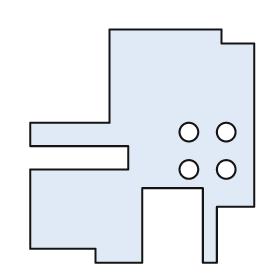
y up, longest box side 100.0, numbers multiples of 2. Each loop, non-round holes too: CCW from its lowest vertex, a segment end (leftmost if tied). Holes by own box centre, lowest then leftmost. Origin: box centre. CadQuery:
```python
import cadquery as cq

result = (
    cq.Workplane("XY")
    .moveTo(-20.0, -50.0)
    .lineTo(0.0, -50.0)
    .lineTo(0.0, -18.0)
    .lineTo(26.0, -18.0)
    .lineTo(26.0, -50.0)
    .lineTo(32.0, -50.0)
    .lineTo(32.0, -26.0)
    .lineTo(48.0, -26.0)
    .lineTo(48.0, 44.0)
    .lineTo(34.0, 44.0)
    .lineTo(34.0, 50.0)
    .lineTo(-14.0, 50.0)
    .lineTo(-14.0, 10.0)
    .lineTo(-48.0, 10.0)
    .lineTo(-48.0, 0.0)
    .lineTo(-6.0, 0.0)
    .lineTo(-6.0, -10.0)
    .lineTo(-48.0, -10.0)
    .lineTo(-48.0, -44.0)
    .lineTo(-20.0, -44.0)
    .close()
    .moveTo(20.0, -10.0)
    .circle(4.0)
    .moveTo(36.0, -10.0)
    .circle(4.0)
    .moveTo(20.0, 6.0)
    .circle(4.0)
    .moveTo(36.0, 6.0)
    .circle(4.0)
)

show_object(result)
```